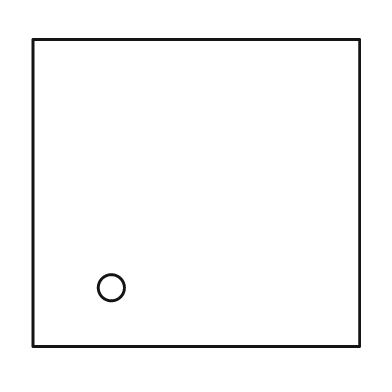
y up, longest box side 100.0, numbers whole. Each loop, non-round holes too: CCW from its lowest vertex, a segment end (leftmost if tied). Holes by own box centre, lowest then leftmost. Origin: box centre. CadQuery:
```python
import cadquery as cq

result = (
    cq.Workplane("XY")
    .moveTo(-50.0, -47.0)
    .lineTo(50.0, -47.0)
    .lineTo(50.0, 47.0)
    .lineTo(-50.0, 47.0)
    .close()
    .moveTo(-26.0, -29.0)
    .circle(4.0)
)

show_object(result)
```